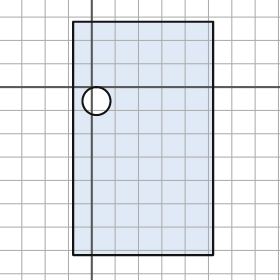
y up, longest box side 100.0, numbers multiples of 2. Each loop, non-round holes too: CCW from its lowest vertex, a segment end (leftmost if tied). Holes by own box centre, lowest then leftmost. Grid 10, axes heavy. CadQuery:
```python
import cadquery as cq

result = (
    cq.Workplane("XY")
    .moveTo(-8.0, -72.0)
    .lineTo(52.0, -72.0)
    .lineTo(52.0, 28.0)
    .lineTo(-8.0, 28.0)
    .close()
    .moveTo(2.0, -6.0)
    .circle(6.0)
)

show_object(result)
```